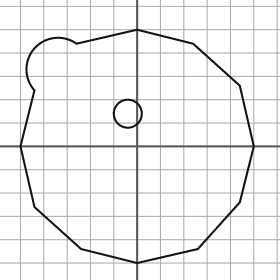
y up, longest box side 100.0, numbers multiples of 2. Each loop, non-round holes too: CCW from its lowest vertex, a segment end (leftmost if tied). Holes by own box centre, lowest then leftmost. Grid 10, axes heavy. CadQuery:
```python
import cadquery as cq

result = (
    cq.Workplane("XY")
    .moveTo(0.0, -50.0)
    .lineTo(26.0, -44.0)
    .lineTo(44.0, -24.0)
    .lineTo(50.0, 0.0)
    .lineTo(44.0, 26.0)
    .lineTo(24.0, 44.0)
    .lineTo(0.0, 50.0)
    .lineTo(-26.0, 44.0)
    .threePointArc((-44.0, 42.0), (-44.0, 24.0))
    .lineTo(-50.0, 0.0)
    .lineTo(-44.0, -26.0)
    .lineTo(-24.0, -44.0)
    .close()
    .moveTo(-4.0, 14.0)
    .circle(6.0)
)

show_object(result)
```